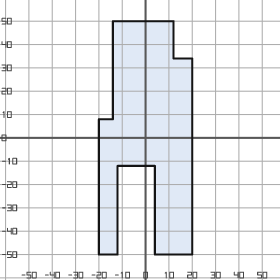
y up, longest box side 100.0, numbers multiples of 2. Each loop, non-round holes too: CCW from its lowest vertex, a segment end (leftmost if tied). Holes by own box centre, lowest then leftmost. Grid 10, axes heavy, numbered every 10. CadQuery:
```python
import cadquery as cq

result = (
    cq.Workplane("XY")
    .moveTo(-20.0, -50.0)
    .lineTo(-12.0, -50.0)
    .lineTo(-12.0, -12.0)
    .lineTo(4.0, -12.0)
    .lineTo(4.0, -50.0)
    .lineTo(20.0, -50.0)
    .lineTo(20.0, 34.0)
    .lineTo(12.0, 34.0)
    .lineTo(12.0, 50.0)
    .lineTo(-14.0, 50.0)
    .lineTo(-14.0, 8.0)
    .lineTo(-20.0, 8.0)
    .close()
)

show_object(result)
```